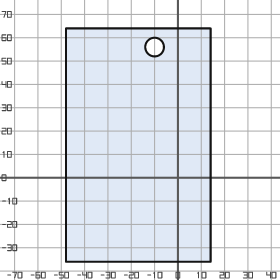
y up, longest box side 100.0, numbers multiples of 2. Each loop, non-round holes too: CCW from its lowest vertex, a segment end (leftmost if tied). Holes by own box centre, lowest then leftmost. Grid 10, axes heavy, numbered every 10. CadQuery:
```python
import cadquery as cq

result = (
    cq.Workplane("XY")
    .moveTo(-48.0, -36.0)
    .lineTo(14.0, -36.0)
    .lineTo(14.0, 64.0)
    .lineTo(-48.0, 64.0)
    .close()
    .moveTo(-10.0, 56.0)
    .circle(4.0)
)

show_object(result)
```